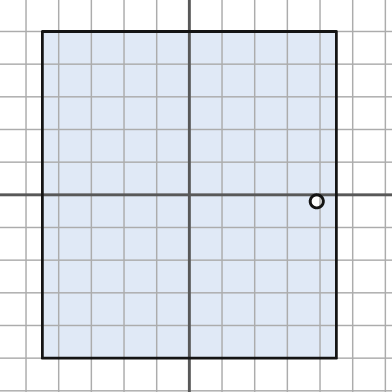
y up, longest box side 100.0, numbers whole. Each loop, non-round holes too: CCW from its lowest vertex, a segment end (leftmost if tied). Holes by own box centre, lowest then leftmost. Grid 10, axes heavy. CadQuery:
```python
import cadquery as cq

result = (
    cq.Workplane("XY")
    .moveTo(-45.0, -50.0)
    .lineTo(45.0, -50.0)
    .lineTo(45.0, 50.0)
    .lineTo(-45.0, 50.0)
    .close()
    .moveTo(39.0, -2.0)
    .circle(2.0)
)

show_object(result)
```